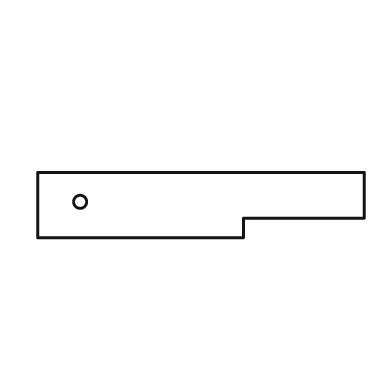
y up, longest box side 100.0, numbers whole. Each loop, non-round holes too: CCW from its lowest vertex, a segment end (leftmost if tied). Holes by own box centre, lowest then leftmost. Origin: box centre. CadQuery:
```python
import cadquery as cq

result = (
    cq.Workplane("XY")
    .moveTo(-50.0, -10.0)
    .lineTo(13.0, -10.0)
    .lineTo(13.0, -4.0)
    .lineTo(50.0, -4.0)
    .lineTo(50.0, 10.0)
    .lineTo(-50.0, 10.0)
    .close()
    .moveTo(-37.0, 1.0)
    .circle(2.0)
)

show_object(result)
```